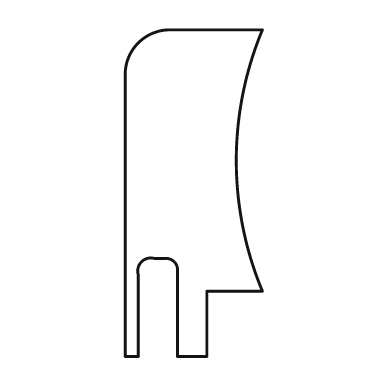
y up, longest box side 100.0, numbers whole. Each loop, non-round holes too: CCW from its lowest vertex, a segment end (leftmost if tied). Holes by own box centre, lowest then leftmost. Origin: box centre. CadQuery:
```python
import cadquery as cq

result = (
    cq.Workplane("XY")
    .moveTo(-21.0, -50.0)
    .lineTo(-17.0, -50.0)
    .lineTo(-17.0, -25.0)
    .threePointArc((-16.0, -21.0), (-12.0, -20.0))
    .lineTo(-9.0, -20.0)
    .threePointArc((-6.0, -21.0), (-5.0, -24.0))
    .lineTo(-5.0, -50.0)
    .lineTo(4.0, -50.0)
    .lineTo(4.0, -30.0)
    .lineTo(21.0, -30.0)
    .threePointArc((13.0, 10.0), (21.0, 50.0))
    .lineTo(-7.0, 50.0)
    .threePointArc((-17.0, 46.0), (-21.0, 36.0))
    .close()
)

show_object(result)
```